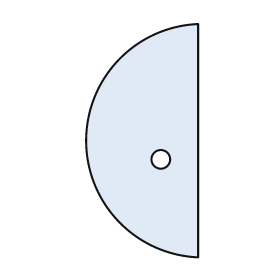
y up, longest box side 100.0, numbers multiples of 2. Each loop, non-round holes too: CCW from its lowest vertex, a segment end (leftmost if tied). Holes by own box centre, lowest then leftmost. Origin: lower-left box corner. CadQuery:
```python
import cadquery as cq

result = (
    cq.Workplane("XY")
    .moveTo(48.0, 0.0)
    .lineTo(48.0, 100.0)
    .threePointArc((0.0, 50.0), (48.0, 0.0))
    .close()
    .moveTo(32.0, 42.0)
    .circle(4.0)
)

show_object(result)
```